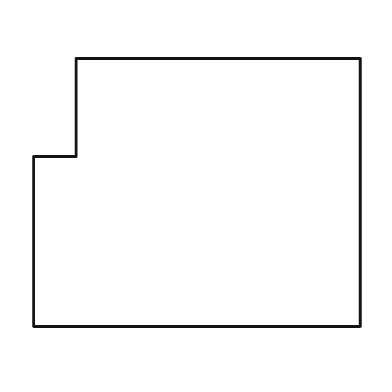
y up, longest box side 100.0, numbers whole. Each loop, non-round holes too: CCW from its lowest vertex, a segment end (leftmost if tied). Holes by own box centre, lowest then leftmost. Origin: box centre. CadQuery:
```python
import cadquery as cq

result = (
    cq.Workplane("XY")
    .moveTo(-50.0, -41.0)
    .lineTo(50.0, -41.0)
    .lineTo(50.0, 41.0)
    .lineTo(-37.0, 41.0)
    .lineTo(-37.0, 11.0)
    .lineTo(-50.0, 11.0)
    .close()
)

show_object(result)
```